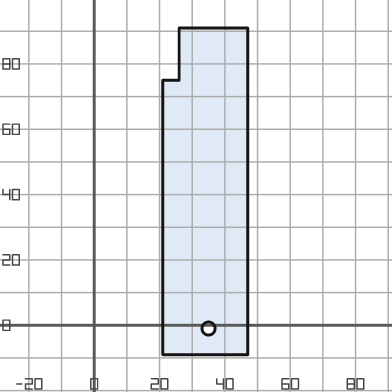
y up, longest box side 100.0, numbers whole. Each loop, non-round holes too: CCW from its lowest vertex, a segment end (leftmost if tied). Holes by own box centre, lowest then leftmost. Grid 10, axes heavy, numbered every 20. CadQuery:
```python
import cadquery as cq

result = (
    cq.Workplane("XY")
    .moveTo(21.0, -9.0)
    .lineTo(47.0, -9.0)
    .lineTo(47.0, 91.0)
    .lineTo(26.0, 91.0)
    .lineTo(26.0, 75.0)
    .lineTo(21.0, 75.0)
    .close()
    .moveTo(35.0, -1.0)
    .circle(2.0)
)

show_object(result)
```